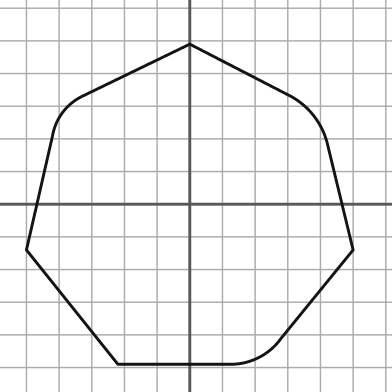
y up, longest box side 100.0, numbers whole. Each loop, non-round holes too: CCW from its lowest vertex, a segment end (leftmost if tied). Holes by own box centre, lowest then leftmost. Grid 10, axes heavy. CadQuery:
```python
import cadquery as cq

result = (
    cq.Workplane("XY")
    .moveTo(-22.0, -49.0)
    .lineTo(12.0, -49.0)
    .threePointArc((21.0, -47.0), (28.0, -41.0))
    .lineTo(50.0, -14.0)
    .lineTo(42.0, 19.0)
    .threePointArc((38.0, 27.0), (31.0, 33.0))
    .lineTo(0.0, 49.0)
    .lineTo(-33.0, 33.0)
    .threePointArc((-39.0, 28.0), (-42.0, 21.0))
    .lineTo(-50.0, -14.0)
    .close()
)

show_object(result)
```